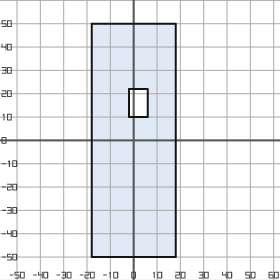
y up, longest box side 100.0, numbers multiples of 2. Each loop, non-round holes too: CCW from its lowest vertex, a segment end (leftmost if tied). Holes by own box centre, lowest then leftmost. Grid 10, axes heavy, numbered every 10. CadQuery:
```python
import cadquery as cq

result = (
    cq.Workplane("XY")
    .moveTo(-18.0, -50.0)
    .lineTo(18.0, -50.0)
    .lineTo(18.0, 50.0)
    .lineTo(-18.0, 50.0)
    .close()
    .moveTo(-2.0, 10.0)
    .lineTo(6.0, 10.0)
    .lineTo(6.0, 22.0)
    .lineTo(-2.0, 22.0)
    .close()
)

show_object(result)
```